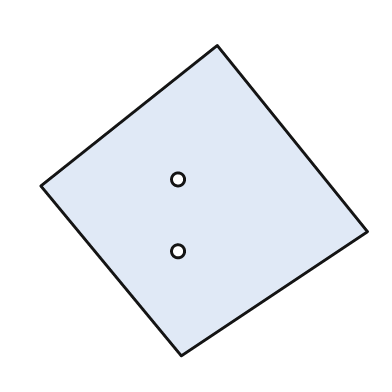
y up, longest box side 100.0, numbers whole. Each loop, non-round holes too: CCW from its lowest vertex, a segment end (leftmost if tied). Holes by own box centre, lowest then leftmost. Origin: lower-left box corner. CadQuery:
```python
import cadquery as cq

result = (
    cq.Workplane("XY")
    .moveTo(43.0, 0.0)
    .lineTo(100.0, 38.0)
    .lineTo(54.0, 95.0)
    .lineTo(0.0, 52.0)
    .close()
    .moveTo(42.0, 32.0)
    .circle(2.0)
    .moveTo(42.0, 54.0)
    .circle(2.0)
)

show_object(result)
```